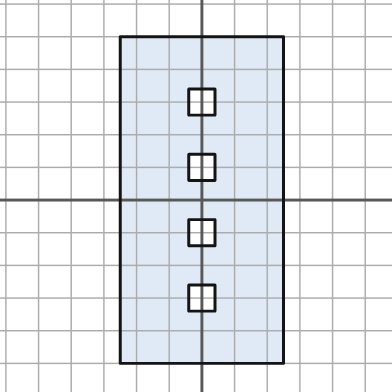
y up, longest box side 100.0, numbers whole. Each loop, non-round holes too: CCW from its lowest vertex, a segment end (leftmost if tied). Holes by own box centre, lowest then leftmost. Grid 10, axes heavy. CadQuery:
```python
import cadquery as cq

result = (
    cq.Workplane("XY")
    .moveTo(-25.0, -50.0)
    .lineTo(25.0, -50.0)
    .lineTo(25.0, 50.0)
    .lineTo(-25.0, 50.0)
    .close()
    .moveTo(-4.0, -34.0)
    .lineTo(4.0, -34.0)
    .lineTo(4.0, -26.0)
    .lineTo(-4.0, -26.0)
    .close()
    .moveTo(-4.0, -14.0)
    .lineTo(4.0, -14.0)
    .lineTo(4.0, -6.0)
    .lineTo(-4.0, -6.0)
    .close()
    .moveTo(-4.0, 6.0)
    .lineTo(4.0, 6.0)
    .lineTo(4.0, 14.0)
    .lineTo(-4.0, 14.0)
    .close()
    .moveTo(-4.0, 26.0)
    .lineTo(4.0, 26.0)
    .lineTo(4.0, 34.0)
    .lineTo(-4.0, 34.0)
    .close()
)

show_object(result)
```